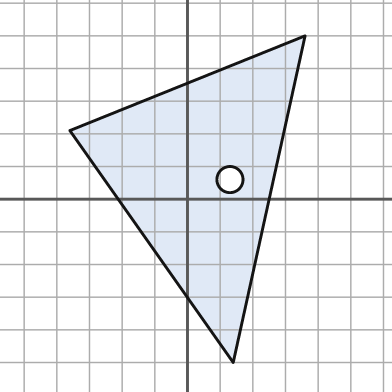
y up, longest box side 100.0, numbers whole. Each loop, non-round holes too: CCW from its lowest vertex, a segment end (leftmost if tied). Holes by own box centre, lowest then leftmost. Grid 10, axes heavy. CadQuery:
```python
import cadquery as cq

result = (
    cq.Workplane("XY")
    .moveTo(14.0, -50.0)
    .lineTo(36.0, 50.0)
    .lineTo(-36.0, 21.0)
    .close()
    .moveTo(13.0, 6.0)
    .circle(4.0)
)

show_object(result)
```